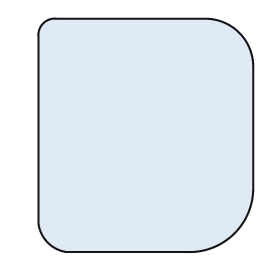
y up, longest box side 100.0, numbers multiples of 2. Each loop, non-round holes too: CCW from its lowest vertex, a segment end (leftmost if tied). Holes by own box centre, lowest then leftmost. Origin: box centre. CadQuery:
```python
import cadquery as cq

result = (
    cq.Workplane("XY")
    .moveTo(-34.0, -50.0)
    .lineTo(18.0, -50.0)
    .threePointArc((38.0, -42.0), (46.0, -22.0))
    .lineTo(46.0, 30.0)
    .threePointArc((40.0, 44.0), (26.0, 50.0))
    .lineTo(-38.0, 50.0)
    .threePointArc((-44.0, 48.0), (-46.0, 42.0))
    .lineTo(-46.0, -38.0)
    .threePointArc((-42.0, -46.0), (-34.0, -50.0))
    .close()
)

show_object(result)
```